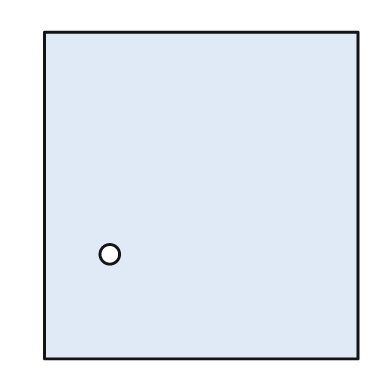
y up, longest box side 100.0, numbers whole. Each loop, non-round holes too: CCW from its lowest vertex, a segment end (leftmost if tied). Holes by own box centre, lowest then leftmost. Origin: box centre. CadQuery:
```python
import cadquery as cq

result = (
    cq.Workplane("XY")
    .moveTo(-48.0, -50.0)
    .lineTo(48.0, -50.0)
    .lineTo(48.0, 50.0)
    .lineTo(-48.0, 50.0)
    .close()
    .moveTo(-28.0, -18.0)
    .circle(3.0)
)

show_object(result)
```